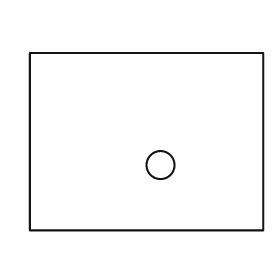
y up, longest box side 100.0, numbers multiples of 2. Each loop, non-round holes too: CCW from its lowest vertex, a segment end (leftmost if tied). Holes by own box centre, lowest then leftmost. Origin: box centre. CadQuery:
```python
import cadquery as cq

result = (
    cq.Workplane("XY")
    .moveTo(-50.0, -38.0)
    .lineTo(50.0, -38.0)
    .lineTo(50.0, 38.0)
    .lineTo(-50.0, 38.0)
    .close()
    .moveTo(6.0, -10.0)
    .circle(6.0)
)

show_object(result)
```